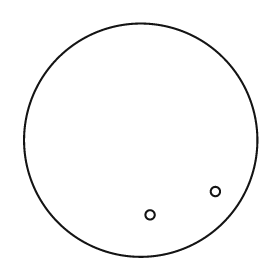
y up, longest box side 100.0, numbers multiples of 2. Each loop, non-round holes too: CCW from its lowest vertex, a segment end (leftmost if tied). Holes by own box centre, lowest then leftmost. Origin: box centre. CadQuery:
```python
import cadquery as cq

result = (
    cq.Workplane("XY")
    .moveTo(0.0, 0.0)
    .circle(50.0)
    .moveTo(4.0, -32.0)
    .circle(2.0)
    .moveTo(32.0, -22.0)
    .circle(2.0)
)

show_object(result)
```